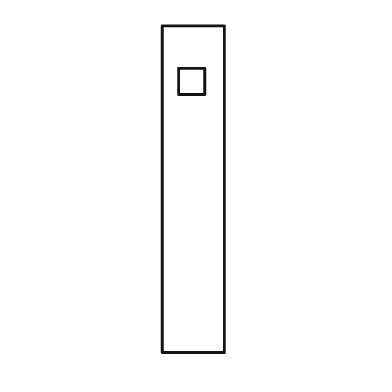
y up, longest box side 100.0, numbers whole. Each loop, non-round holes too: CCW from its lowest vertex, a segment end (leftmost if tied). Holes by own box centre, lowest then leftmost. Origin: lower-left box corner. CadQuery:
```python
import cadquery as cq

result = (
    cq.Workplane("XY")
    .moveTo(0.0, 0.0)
    .lineTo(19.0, 0.0)
    .lineTo(19.0, 100.0)
    .lineTo(0.0, 100.0)
    .close()
    .moveTo(5.0, 79.0)
    .lineTo(13.0, 79.0)
    .lineTo(13.0, 87.0)
    .lineTo(5.0, 87.0)
    .close()
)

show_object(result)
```